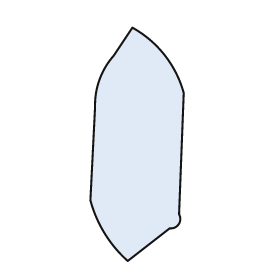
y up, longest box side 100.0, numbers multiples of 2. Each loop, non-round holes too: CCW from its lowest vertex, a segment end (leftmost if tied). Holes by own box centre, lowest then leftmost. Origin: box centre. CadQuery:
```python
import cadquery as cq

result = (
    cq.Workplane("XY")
    .moveTo(-4.0, -50.0)
    .lineTo(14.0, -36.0)
    .threePointArc((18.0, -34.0), (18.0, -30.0))
    .lineTo(20.0, 22.0)
    .threePointArc((12.0, 38.0), (-2.0, 50.0))
    .lineTo(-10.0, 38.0)
    .threePointArc((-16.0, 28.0), (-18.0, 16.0))
    .lineTo(-20.0, -24.0)
    .threePointArc((-14.0, -38.0), (-4.0, -50.0))
    .close()
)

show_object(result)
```